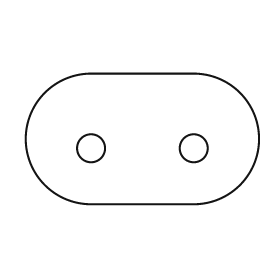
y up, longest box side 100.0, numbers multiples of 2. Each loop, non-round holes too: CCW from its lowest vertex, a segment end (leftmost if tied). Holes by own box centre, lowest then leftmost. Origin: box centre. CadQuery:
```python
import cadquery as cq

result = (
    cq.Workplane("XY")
    .moveTo(-22.0, -28.0)
    .lineTo(22.0, -28.0)
    .threePointArc((50.0, 0.0), (22.0, 28.0))
    .lineTo(-22.0, 28.0)
    .threePointArc((-50.0, 0.0), (-22.0, -28.0))
    .close()
    .moveTo(-22.0, -4.0)
    .circle(6.0)
    .moveTo(22.0, -4.0)
    .circle(6.0)
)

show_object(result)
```